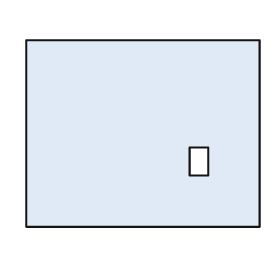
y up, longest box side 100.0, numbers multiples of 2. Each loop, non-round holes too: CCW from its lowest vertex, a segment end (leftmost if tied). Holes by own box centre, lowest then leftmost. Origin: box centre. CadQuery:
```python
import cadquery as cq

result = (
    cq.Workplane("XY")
    .moveTo(-50.0, -40.0)
    .lineTo(50.0, -40.0)
    .lineTo(50.0, 40.0)
    .lineTo(-50.0, 40.0)
    .close()
    .moveTo(20.0, -18.0)
    .lineTo(28.0, -18.0)
    .lineTo(28.0, -6.0)
    .lineTo(20.0, -6.0)
    .close()
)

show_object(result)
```